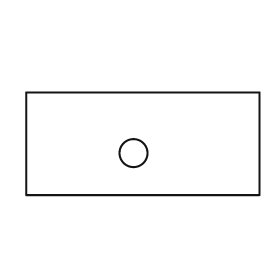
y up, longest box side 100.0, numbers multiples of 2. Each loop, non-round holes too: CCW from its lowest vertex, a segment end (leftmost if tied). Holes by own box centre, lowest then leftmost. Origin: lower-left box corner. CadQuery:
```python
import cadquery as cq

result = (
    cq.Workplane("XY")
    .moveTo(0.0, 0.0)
    .lineTo(100.0, 0.0)
    .lineTo(100.0, 44.0)
    .lineTo(0.0, 44.0)
    .close()
    .moveTo(46.0, 18.0)
    .circle(6.0)
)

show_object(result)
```